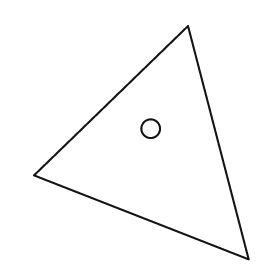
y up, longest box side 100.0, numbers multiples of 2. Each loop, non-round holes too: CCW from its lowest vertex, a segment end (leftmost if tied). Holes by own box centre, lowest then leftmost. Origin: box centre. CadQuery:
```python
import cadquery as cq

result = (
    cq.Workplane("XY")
    .moveTo(46.0, -50.0)
    .lineTo(20.0, 50.0)
    .lineTo(-46.0, -14.0)
    .close()
    .moveTo(4.0, 6.0)
    .circle(4.0)
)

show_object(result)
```